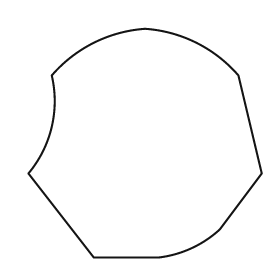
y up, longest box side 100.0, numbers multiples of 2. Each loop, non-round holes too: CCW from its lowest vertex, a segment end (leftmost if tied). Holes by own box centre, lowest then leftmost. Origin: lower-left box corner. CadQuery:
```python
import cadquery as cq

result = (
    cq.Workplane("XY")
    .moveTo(28.0, 0.0)
    .lineTo(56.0, 0.0)
    .threePointArc((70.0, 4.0), (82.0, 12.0))
    .lineTo(100.0, 36.0)
    .lineTo(90.0, 78.0)
    .threePointArc((72.0, 92.0), (50.0, 98.0))
    .threePointArc((28.0, 92.0), (10.0, 78.0))
    .threePointArc((10.0, 56.0), (0.0, 36.0))
    .close()
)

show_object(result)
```